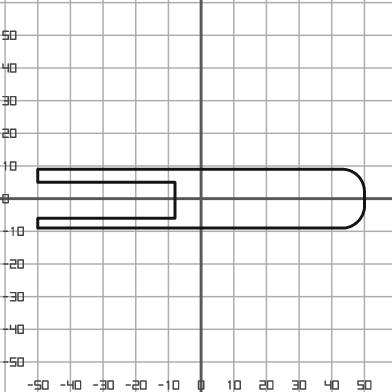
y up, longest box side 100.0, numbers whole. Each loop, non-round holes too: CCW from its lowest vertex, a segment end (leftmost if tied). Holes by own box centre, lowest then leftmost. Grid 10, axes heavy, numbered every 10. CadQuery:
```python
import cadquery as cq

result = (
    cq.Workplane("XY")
    .moveTo(-50.0, -9.0)
    .lineTo(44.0, -9.0)
    .threePointArc((48.0, -7.0), (50.0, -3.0))
    .lineTo(50.0, 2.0)
    .threePointArc((48.0, 7.0), (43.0, 9.0))
    .lineTo(-50.0, 9.0)
    .lineTo(-50.0, 5.0)
    .lineTo(-8.0, 5.0)
    .lineTo(-8.0, -6.0)
    .lineTo(-50.0, -6.0)
    .close()
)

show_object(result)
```